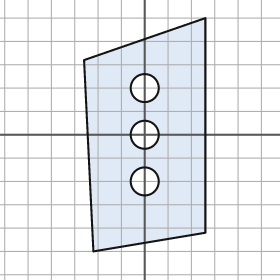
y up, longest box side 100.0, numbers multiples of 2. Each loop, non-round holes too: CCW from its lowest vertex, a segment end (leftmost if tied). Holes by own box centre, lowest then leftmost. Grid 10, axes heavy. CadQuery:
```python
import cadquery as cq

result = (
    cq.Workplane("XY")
    .moveTo(-22.0, -50.0)
    .lineTo(26.0, -42.0)
    .lineTo(26.0, 50.0)
    .lineTo(-26.0, 32.0)
    .close()
    .moveTo(0.0, -20.0)
    .circle(6.0)
    .moveTo(0.0, 0.0)
    .circle(6.0)
    .moveTo(0.0, 20.0)
    .circle(6.0)
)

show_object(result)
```